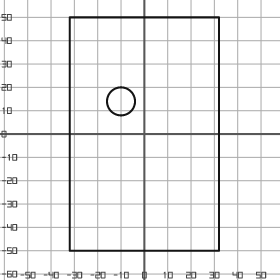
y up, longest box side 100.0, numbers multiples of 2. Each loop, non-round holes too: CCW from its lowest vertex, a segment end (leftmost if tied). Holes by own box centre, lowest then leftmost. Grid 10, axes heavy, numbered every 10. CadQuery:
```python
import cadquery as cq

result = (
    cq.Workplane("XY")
    .moveTo(-32.0, -50.0)
    .lineTo(32.0, -50.0)
    .lineTo(32.0, 50.0)
    .lineTo(-32.0, 50.0)
    .close()
    .moveTo(-10.0, 14.0)
    .circle(6.0)
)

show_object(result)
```